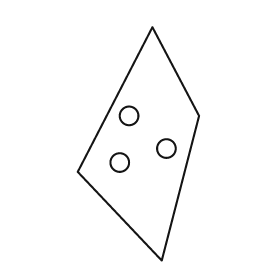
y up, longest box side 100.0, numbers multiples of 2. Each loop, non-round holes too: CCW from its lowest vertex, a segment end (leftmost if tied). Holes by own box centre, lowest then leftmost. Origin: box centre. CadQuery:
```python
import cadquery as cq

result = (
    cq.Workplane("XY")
    .moveTo(10.0, -50.0)
    .lineTo(26.0, 12.0)
    .lineTo(6.0, 50.0)
    .lineTo(-26.0, -12.0)
    .close()
    .moveTo(-8.0, -8.0)
    .circle(4.0)
    .moveTo(12.0, -2.0)
    .circle(4.0)
    .moveTo(-4.0, 12.0)
    .circle(4.0)
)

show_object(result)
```